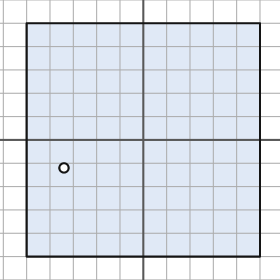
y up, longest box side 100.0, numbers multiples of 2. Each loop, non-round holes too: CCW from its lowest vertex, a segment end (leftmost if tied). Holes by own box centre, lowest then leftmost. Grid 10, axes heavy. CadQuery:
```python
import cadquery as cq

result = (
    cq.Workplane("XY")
    .moveTo(-50.0, -50.0)
    .lineTo(50.0, -50.0)
    .lineTo(50.0, 50.0)
    .lineTo(-50.0, 50.0)
    .close()
    .moveTo(-34.0, -12.0)
    .circle(2.0)
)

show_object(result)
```